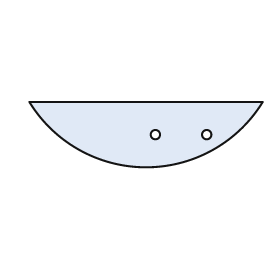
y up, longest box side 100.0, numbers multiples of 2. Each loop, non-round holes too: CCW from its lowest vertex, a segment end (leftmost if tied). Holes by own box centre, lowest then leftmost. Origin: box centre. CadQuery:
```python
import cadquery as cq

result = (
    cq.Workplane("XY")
    .moveTo(-50.0, 14.0)
    .threePointArc((0.0, -14.0), (50.0, 14.0))
    .close()
    .moveTo(4.0, 0.0)
    .circle(2.0)
    .moveTo(26.0, 0.0)
    .circle(2.0)
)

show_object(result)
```